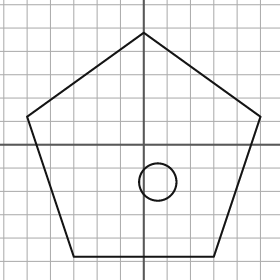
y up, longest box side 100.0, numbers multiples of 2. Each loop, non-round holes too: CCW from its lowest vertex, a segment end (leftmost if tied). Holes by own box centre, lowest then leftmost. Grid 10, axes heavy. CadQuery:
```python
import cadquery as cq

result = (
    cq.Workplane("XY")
    .moveTo(-30.0, -48.0)
    .lineTo(30.0, -48.0)
    .lineTo(50.0, 12.0)
    .lineTo(0.0, 48.0)
    .lineTo(-50.0, 12.0)
    .close()
    .moveTo(6.0, -16.0)
    .circle(8.0)
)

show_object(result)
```